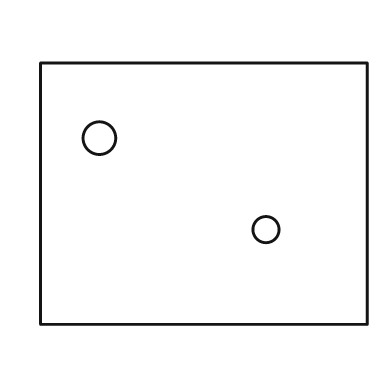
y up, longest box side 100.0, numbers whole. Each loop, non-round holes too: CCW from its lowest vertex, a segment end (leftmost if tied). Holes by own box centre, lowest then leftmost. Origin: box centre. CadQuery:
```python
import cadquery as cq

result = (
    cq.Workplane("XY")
    .moveTo(-50.0, -40.0)
    .lineTo(50.0, -40.0)
    .lineTo(50.0, 40.0)
    .lineTo(-50.0, 40.0)
    .close()
    .moveTo(19.0, -11.0)
    .circle(4.0)
    .moveTo(-32.0, 17.0)
    .circle(5.0)
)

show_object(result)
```